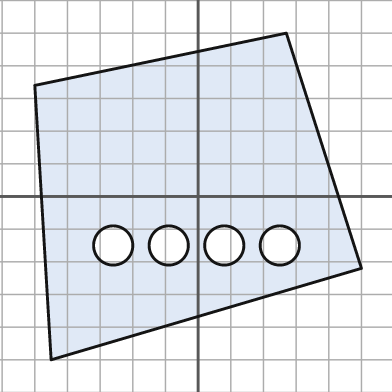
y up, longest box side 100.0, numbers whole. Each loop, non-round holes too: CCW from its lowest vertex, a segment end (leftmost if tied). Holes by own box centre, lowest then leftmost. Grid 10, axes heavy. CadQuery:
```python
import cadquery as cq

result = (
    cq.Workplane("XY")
    .moveTo(-45.0, -50.0)
    .lineTo(50.0, -22.0)
    .lineTo(27.0, 50.0)
    .lineTo(-50.0, 34.0)
    .close()
    .moveTo(-26.0, -15.0)
    .circle(6.0)
    .moveTo(-9.0, -15.0)
    .circle(6.0)
    .moveTo(8.0, -15.0)
    .circle(6.0)
    .moveTo(25.0, -15.0)
    .circle(6.0)
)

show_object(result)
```